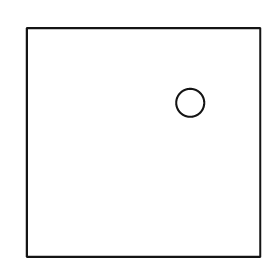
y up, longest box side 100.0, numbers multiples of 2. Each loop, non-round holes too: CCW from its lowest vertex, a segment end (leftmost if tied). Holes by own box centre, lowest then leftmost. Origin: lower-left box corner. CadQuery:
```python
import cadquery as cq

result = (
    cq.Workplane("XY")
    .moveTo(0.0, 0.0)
    .lineTo(100.0, 0.0)
    .lineTo(100.0, 98.0)
    .lineTo(0.0, 98.0)
    .close()
    .moveTo(70.0, 66.0)
    .circle(6.0)
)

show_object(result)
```